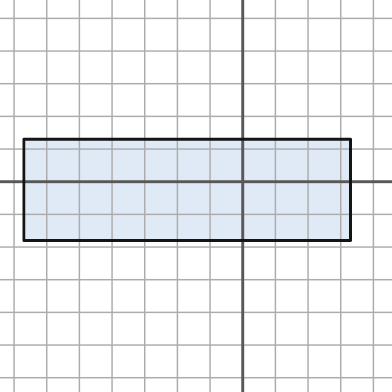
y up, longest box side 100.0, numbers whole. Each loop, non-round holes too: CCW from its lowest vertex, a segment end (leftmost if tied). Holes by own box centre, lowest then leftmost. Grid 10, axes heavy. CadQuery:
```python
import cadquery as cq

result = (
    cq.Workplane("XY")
    .moveTo(-67.0, -18.0)
    .lineTo(33.0, -18.0)
    .lineTo(33.0, 13.0)
    .lineTo(-67.0, 13.0)
    .close()
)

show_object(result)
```